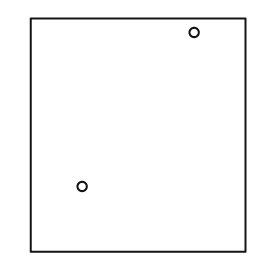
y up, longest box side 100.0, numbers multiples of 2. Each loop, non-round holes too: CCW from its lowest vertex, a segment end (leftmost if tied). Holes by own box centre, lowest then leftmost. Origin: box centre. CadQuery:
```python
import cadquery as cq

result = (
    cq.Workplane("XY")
    .moveTo(-46.0, -50.0)
    .lineTo(46.0, -50.0)
    .lineTo(46.0, 50.0)
    .lineTo(-46.0, 50.0)
    .close()
    .moveTo(-24.0, -22.0)
    .circle(2.0)
    .moveTo(24.0, 44.0)
    .circle(2.0)
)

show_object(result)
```